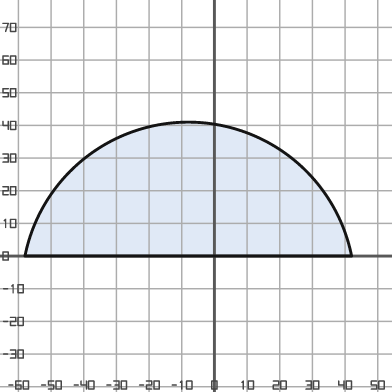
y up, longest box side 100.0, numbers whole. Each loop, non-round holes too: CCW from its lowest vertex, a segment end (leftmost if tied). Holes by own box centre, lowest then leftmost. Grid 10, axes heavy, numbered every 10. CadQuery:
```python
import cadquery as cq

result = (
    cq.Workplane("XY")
    .moveTo(-58.0, 0.0)
    .lineTo(42.0, 0.0)
    .threePointArc((-8.0, 41.0), (-58.0, 0.0))
    .close()
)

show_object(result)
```